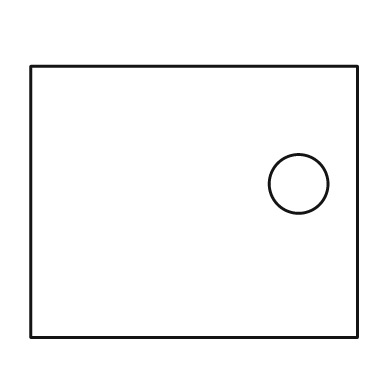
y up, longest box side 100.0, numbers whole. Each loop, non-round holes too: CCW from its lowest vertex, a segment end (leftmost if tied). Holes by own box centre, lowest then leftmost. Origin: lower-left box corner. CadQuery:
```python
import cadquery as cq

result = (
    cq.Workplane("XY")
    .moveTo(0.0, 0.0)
    .lineTo(100.0, 0.0)
    .lineTo(100.0, 83.0)
    .lineTo(0.0, 83.0)
    .close()
    .moveTo(82.0, 47.0)
    .circle(9.0)
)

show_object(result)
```